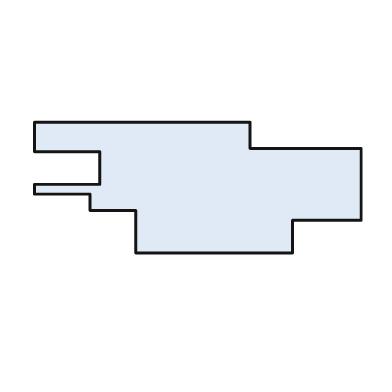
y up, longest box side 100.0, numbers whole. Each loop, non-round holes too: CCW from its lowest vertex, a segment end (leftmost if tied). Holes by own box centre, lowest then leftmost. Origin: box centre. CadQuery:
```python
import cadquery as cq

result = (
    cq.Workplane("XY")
    .moveTo(-19.0, -20.0)
    .lineTo(29.0, -20.0)
    .lineTo(29.0, -10.0)
    .lineTo(50.0, -10.0)
    .lineTo(50.0, 12.0)
    .lineTo(16.0, 12.0)
    .lineTo(16.0, 20.0)
    .lineTo(-50.0, 20.0)
    .lineTo(-50.0, 11.0)
    .lineTo(-30.0, 11.0)
    .lineTo(-30.0, 1.0)
    .lineTo(-50.0, 1.0)
    .lineTo(-50.0, -2.0)
    .lineTo(-33.0, -2.0)
    .lineTo(-33.0, -7.0)
    .lineTo(-19.0, -7.0)
    .close()
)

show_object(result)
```